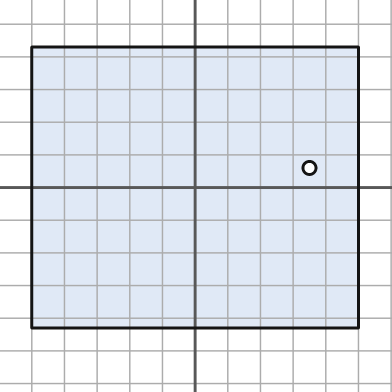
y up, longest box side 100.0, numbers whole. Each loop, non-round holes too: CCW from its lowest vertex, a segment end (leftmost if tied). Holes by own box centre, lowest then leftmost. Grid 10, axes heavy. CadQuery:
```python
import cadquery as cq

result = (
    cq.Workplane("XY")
    .moveTo(-50.0, -43.0)
    .lineTo(50.0, -43.0)
    .lineTo(50.0, 43.0)
    .lineTo(-50.0, 43.0)
    .close()
    .moveTo(35.0, 6.0)
    .circle(2.0)
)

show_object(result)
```